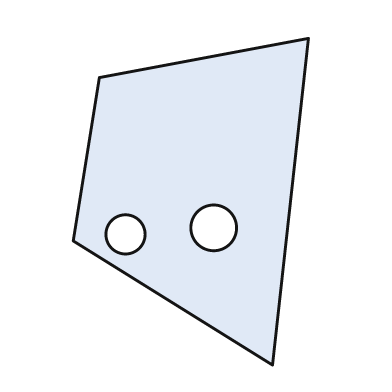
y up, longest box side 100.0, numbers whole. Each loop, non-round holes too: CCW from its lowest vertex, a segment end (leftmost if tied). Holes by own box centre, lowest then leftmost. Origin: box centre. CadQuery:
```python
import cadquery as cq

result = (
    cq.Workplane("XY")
    .moveTo(25.0, -50.0)
    .lineTo(36.0, 50.0)
    .lineTo(-28.0, 38.0)
    .lineTo(-36.0, -12.0)
    .close()
    .moveTo(-20.0, -10.0)
    .circle(6.0)
    .moveTo(7.0, -8.0)
    .circle(7.0)
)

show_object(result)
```